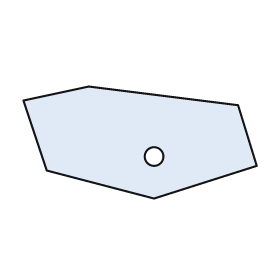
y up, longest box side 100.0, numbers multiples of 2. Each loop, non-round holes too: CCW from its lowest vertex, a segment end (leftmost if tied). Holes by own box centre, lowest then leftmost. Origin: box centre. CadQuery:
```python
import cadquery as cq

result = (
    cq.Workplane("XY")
    .moveTo(6.0, -24.0)
    .lineTo(50.0, -10.0)
    .lineTo(42.0, 16.0)
    .lineTo(-22.0, 24.0)
    .lineTo(-50.0, 18.0)
    .lineTo(-40.0, -12.0)
    .close()
    .moveTo(6.0, -6.0)
    .circle(4.0)
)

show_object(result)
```